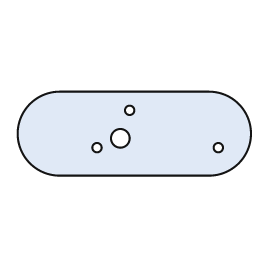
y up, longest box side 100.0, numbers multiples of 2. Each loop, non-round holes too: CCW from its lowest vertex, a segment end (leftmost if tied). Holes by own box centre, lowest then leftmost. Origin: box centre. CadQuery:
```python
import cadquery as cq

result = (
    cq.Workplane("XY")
    .moveTo(-32.0, -18.0)
    .lineTo(32.0, -18.0)
    .threePointArc((50.0, 0.0), (32.0, 18.0))
    .lineTo(-32.0, 18.0)
    .threePointArc((-50.0, 0.0), (-32.0, -18.0))
    .close()
    .moveTo(-16.0, -6.0)
    .circle(2.0)
    .moveTo(36.0, -6.0)
    .circle(2.0)
    .moveTo(-6.0, -2.0)
    .circle(4.0)
    .moveTo(-2.0, 10.0)
    .circle(2.0)
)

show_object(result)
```